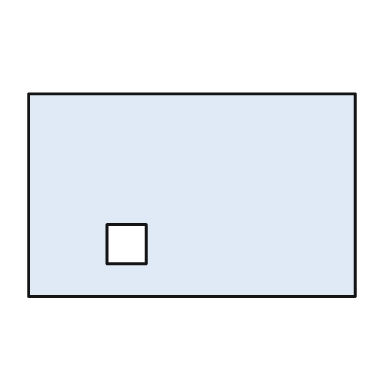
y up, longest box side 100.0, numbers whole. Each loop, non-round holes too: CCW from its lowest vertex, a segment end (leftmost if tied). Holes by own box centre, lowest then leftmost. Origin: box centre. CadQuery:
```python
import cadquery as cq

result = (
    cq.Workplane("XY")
    .moveTo(-50.0, -31.0)
    .lineTo(50.0, -31.0)
    .lineTo(50.0, 31.0)
    .lineTo(-50.0, 31.0)
    .close()
    .moveTo(-26.0, -21.0)
    .lineTo(-14.0, -21.0)
    .lineTo(-14.0, -9.0)
    .lineTo(-26.0, -9.0)
    .close()
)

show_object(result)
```